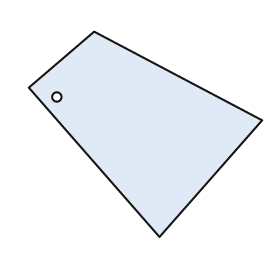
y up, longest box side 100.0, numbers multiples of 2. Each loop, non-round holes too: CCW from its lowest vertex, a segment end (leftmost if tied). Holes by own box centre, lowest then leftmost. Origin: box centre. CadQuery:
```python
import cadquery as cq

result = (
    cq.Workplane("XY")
    .moveTo(6.0, -44.0)
    .lineTo(50.0, 6.0)
    .lineTo(-22.0, 44.0)
    .lineTo(-50.0, 20.0)
    .close()
    .moveTo(-38.0, 16.0)
    .circle(2.0)
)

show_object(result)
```